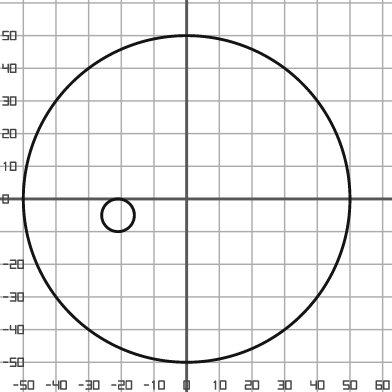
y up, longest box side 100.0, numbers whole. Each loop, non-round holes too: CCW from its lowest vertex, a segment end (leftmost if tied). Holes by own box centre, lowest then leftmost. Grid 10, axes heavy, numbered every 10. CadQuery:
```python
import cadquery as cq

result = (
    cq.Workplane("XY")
    .moveTo(0.0, 0.0)
    .circle(50.0)
    .moveTo(-21.0, -5.0)
    .circle(5.0)
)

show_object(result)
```